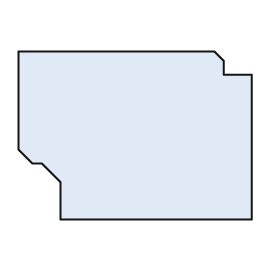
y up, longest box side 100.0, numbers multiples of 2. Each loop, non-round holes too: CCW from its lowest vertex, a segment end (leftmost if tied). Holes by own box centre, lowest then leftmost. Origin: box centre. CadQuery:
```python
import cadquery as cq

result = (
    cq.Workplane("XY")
    .moveTo(-32.0, -36.0)
    .lineTo(50.0, -36.0)
    .lineTo(50.0, 26.0)
    .lineTo(38.0, 26.0)
    .lineTo(38.0, 32.0)
    .lineTo(34.0, 36.0)
    .lineTo(-50.0, 36.0)
    .lineTo(-50.0, -6.0)
    .lineTo(-44.0, -12.0)
    .lineTo(-40.0, -12.0)
    .lineTo(-32.0, -20.0)
    .close()
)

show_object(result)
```